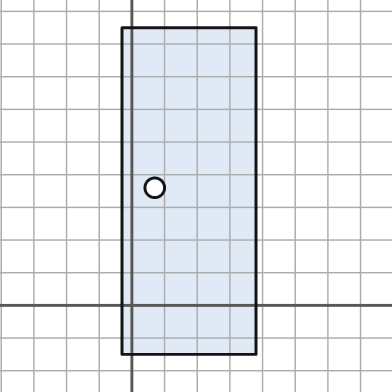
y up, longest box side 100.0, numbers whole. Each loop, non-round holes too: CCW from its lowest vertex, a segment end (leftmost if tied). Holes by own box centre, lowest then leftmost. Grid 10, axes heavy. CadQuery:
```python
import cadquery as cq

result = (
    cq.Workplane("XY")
    .moveTo(-3.0, -15.0)
    .lineTo(38.0, -15.0)
    .lineTo(38.0, 85.0)
    .lineTo(-3.0, 85.0)
    .close()
    .moveTo(7.0, 36.0)
    .circle(3.0)
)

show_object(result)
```